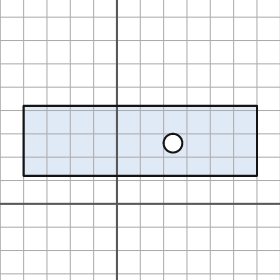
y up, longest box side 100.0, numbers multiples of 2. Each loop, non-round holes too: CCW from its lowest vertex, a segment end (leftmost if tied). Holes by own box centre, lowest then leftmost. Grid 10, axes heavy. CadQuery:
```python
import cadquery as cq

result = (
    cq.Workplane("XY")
    .moveTo(-40.0, 12.0)
    .lineTo(60.0, 12.0)
    .lineTo(60.0, 42.0)
    .lineTo(-40.0, 42.0)
    .close()
    .moveTo(24.0, 26.0)
    .circle(4.0)
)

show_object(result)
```